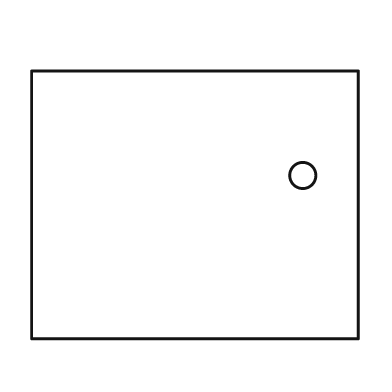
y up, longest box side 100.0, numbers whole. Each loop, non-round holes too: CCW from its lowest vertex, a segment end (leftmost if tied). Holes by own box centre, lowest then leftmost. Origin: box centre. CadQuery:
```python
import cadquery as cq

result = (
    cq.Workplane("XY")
    .moveTo(-50.0, -41.0)
    .lineTo(50.0, -41.0)
    .lineTo(50.0, 41.0)
    .lineTo(-50.0, 41.0)
    .close()
    .moveTo(33.0, 9.0)
    .circle(4.0)
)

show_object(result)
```